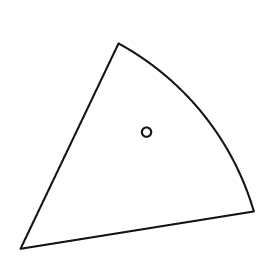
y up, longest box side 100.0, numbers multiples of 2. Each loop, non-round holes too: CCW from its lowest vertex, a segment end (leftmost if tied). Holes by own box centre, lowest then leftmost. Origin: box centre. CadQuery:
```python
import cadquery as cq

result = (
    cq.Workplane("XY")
    .moveTo(-50.0, -44.0)
    .lineTo(50.0, -28.0)
    .threePointArc((28.0, 14.0), (-8.0, 44.0))
    .close()
    .moveTo(4.0, 6.0)
    .circle(2.0)
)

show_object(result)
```